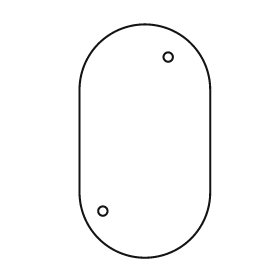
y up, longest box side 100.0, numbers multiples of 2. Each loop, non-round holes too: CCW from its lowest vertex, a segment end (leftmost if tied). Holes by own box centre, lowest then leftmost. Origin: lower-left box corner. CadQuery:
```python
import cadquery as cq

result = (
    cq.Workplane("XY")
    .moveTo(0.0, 28.0)
    .threePointArc((28.0, 0.0), (56.0, 28.0))
    .lineTo(56.0, 72.0)
    .threePointArc((28.0, 100.0), (0.0, 72.0))
    .close()
    .moveTo(10.0, 20.0)
    .circle(2.0)
    .moveTo(38.0, 86.0)
    .circle(2.0)
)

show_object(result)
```